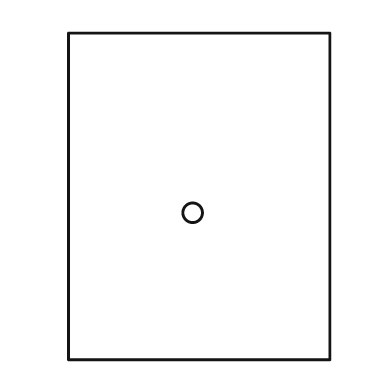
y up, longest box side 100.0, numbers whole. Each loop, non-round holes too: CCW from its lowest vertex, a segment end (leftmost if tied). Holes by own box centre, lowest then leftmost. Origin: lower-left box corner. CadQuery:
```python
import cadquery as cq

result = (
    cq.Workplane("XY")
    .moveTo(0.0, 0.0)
    .lineTo(80.0, 0.0)
    .lineTo(80.0, 100.0)
    .lineTo(0.0, 100.0)
    .close()
    .moveTo(38.0, 45.0)
    .circle(3.0)
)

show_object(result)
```